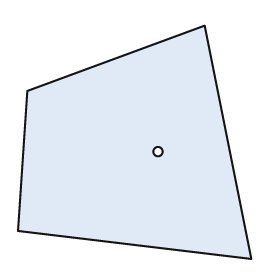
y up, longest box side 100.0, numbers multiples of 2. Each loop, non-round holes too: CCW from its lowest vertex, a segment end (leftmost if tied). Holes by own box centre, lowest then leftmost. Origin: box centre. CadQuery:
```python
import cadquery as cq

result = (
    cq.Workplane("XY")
    .moveTo(50.0, -50.0)
    .lineTo(30.0, 50.0)
    .lineTo(-46.0, 22.0)
    .lineTo(-50.0, -38.0)
    .close()
    .moveTo(10.0, -4.0)
    .circle(2.0)
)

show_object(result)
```